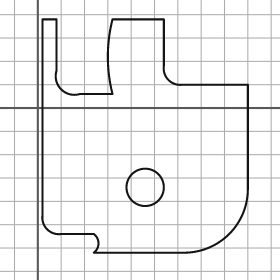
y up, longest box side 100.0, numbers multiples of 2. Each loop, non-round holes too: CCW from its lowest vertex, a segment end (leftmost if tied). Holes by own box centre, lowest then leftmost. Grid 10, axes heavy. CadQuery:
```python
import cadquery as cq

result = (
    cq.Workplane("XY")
    .moveTo(24.0, -62.0)
    .lineTo(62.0, -62.0)
    .threePointArc((82.0, -54.0), (90.0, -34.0))
    .lineTo(90.0, 10.0)
    .lineTo(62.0, 10.0)
    .threePointArc((56.0, 12.0), (54.0, 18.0))
    .lineTo(54.0, 38.0)
    .lineTo(32.0, 38.0)
    .threePointArc((30.0, 22.0), (32.0, 6.0))
    .lineTo(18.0, 6.0)
    .threePointArc((10.0, 8.0), (8.0, 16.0))
    .lineTo(8.0, 38.0)
    .lineTo(2.0, 38.0)
    .lineTo(2.0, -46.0)
    .threePointArc((4.0, -52.0), (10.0, -54.0))
    .lineTo(24.0, -54.0)
    .threePointArc((26.0, -58.0), (24.0, -62.0))
    .close()
    .moveTo(46.0, -34.0)
    .circle(8.0)
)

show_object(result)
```